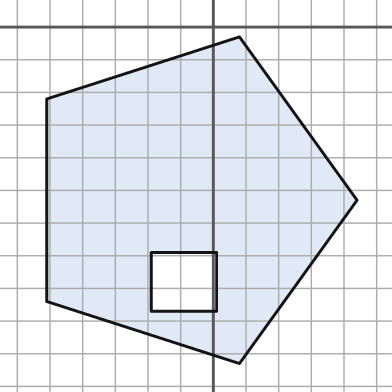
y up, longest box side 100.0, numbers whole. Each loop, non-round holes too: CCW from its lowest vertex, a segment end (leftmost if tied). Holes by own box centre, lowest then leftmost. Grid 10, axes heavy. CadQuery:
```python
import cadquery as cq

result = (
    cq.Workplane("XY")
    .moveTo(8.0, -103.0)
    .lineTo(44.0, -53.0)
    .lineTo(8.0, -3.0)
    .lineTo(-51.0, -22.0)
    .lineTo(-51.0, -84.0)
    .close()
    .moveTo(-19.0, -87.0)
    .lineTo(1.0, -87.0)
    .lineTo(1.0, -69.0)
    .lineTo(-19.0, -69.0)
    .close()
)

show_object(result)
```